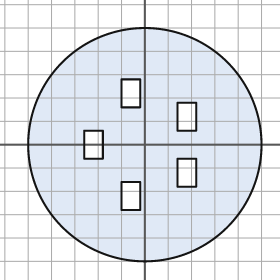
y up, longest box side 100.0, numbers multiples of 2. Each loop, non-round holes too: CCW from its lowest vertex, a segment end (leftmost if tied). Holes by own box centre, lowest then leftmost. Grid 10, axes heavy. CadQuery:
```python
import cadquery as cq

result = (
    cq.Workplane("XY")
    .moveTo(0.0, 0.0)
    .circle(50.0)
    .moveTo(-10.0, -28.0)
    .lineTo(-2.0, -28.0)
    .lineTo(-2.0, -16.0)
    .lineTo(-10.0, -16.0)
    .close()
    .moveTo(14.0, -18.0)
    .lineTo(22.0, -18.0)
    .lineTo(22.0, -6.0)
    .lineTo(14.0, -6.0)
    .close()
    .moveTo(-26.0, -6.0)
    .lineTo(-18.0, -6.0)
    .lineTo(-18.0, 6.0)
    .lineTo(-26.0, 6.0)
    .close()
    .moveTo(14.0, 6.0)
    .lineTo(22.0, 6.0)
    .lineTo(22.0, 18.0)
    .lineTo(14.0, 18.0)
    .close()
    .moveTo(-10.0, 16.0)
    .lineTo(-2.0, 16.0)
    .lineTo(-2.0, 28.0)
    .lineTo(-10.0, 28.0)
    .close()
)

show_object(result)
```